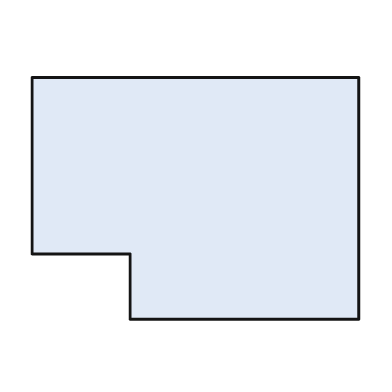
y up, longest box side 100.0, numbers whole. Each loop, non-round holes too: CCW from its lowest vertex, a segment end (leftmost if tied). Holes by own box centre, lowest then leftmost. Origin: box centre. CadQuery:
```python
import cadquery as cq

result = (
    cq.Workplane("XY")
    .moveTo(-20.0, -37.0)
    .lineTo(50.0, -37.0)
    .lineTo(50.0, 37.0)
    .lineTo(-50.0, 37.0)
    .lineTo(-50.0, -17.0)
    .lineTo(-20.0, -17.0)
    .close()
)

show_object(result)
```